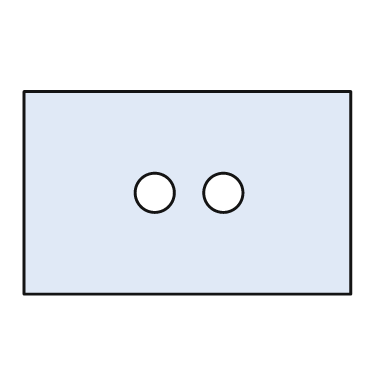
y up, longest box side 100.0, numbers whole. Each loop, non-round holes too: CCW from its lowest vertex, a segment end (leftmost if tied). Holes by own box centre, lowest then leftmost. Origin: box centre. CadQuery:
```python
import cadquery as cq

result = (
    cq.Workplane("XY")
    .moveTo(-50.0, -31.0)
    .lineTo(50.0, -31.0)
    .lineTo(50.0, 31.0)
    .lineTo(-50.0, 31.0)
    .close()
    .moveTo(-10.0, 0.0)
    .circle(6.0)
    .moveTo(11.0, 0.0)
    .circle(6.0)
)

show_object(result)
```